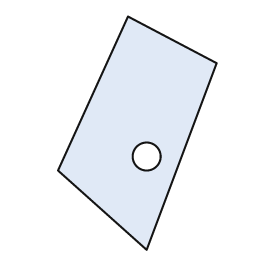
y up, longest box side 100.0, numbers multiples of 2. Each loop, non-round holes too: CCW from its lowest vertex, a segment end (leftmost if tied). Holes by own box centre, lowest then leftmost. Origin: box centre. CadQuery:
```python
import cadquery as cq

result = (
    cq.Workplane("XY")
    .moveTo(4.0, -50.0)
    .lineTo(34.0, 30.0)
    .lineTo(-4.0, 50.0)
    .lineTo(-34.0, -16.0)
    .close()
    .moveTo(4.0, -10.0)
    .circle(6.0)
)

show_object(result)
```